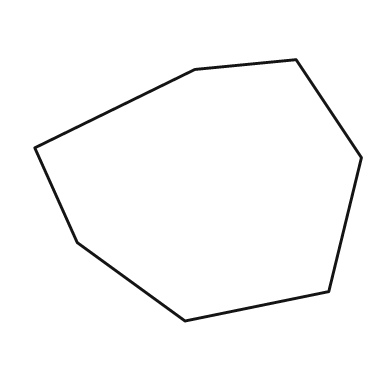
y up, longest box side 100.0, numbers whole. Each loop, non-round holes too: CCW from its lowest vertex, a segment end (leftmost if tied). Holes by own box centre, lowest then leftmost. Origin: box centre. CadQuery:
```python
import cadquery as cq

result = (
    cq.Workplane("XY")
    .moveTo(-4.0, -40.0)
    .lineTo(40.0, -31.0)
    .lineTo(50.0, 10.0)
    .lineTo(30.0, 40.0)
    .lineTo(-1.0, 37.0)
    .lineTo(-50.0, 13.0)
    .lineTo(-37.0, -16.0)
    .close()
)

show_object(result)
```